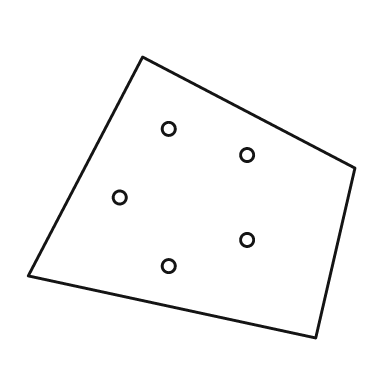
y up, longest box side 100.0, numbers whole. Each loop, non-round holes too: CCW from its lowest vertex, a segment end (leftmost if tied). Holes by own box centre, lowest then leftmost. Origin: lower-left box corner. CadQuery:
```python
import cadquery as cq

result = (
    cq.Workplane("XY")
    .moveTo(88.0, 0.0)
    .lineTo(100.0, 52.0)
    .lineTo(35.0, 86.0)
    .lineTo(0.0, 19.0)
    .close()
    .moveTo(43.0, 22.0)
    .circle(2.0)
    .moveTo(67.0, 30.0)
    .circle(2.0)
    .moveTo(28.0, 43.0)
    .circle(2.0)
    .moveTo(67.0, 56.0)
    .circle(2.0)
    .moveTo(43.0, 64.0)
    .circle(2.0)
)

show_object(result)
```